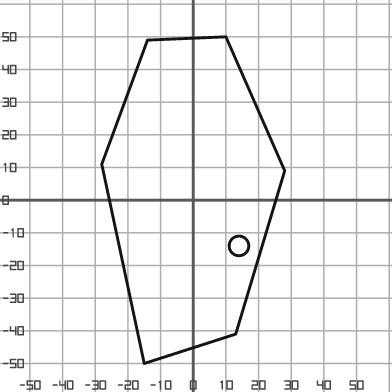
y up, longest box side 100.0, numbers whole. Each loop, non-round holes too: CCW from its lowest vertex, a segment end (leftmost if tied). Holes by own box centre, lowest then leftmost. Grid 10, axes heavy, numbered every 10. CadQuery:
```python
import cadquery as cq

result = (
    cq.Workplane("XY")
    .moveTo(-15.0, -50.0)
    .lineTo(13.0, -41.0)
    .lineTo(28.0, 9.0)
    .lineTo(10.0, 50.0)
    .lineTo(-14.0, 49.0)
    .lineTo(-28.0, 11.0)
    .close()
    .moveTo(14.0, -14.0)
    .circle(3.0)
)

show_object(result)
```